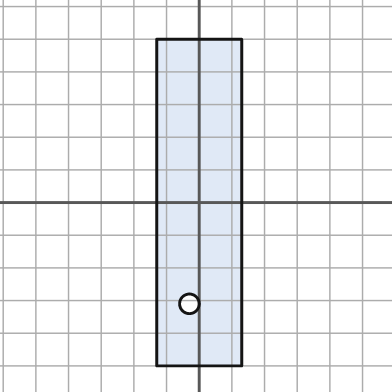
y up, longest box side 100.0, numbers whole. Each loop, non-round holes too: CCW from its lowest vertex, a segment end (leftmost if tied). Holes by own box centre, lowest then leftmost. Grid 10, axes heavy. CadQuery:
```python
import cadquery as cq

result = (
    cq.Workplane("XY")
    .moveTo(-13.0, -50.0)
    .lineTo(13.0, -50.0)
    .lineTo(13.0, 50.0)
    .lineTo(-13.0, 50.0)
    .close()
    .moveTo(-3.0, -31.0)
    .circle(3.0)
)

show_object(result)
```